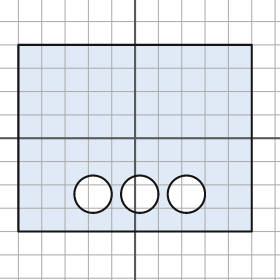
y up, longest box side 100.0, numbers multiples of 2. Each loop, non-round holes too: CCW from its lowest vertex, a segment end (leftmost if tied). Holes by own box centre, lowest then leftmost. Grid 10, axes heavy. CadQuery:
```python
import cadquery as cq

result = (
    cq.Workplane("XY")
    .moveTo(-50.0, -40.0)
    .lineTo(50.0, -40.0)
    .lineTo(50.0, 40.0)
    .lineTo(-50.0, 40.0)
    .close()
    .moveTo(-18.0, -24.0)
    .circle(8.0)
    .moveTo(2.0, -24.0)
    .circle(8.0)
    .moveTo(22.0, -24.0)
    .circle(8.0)
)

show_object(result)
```